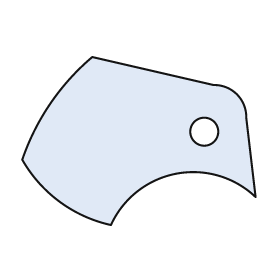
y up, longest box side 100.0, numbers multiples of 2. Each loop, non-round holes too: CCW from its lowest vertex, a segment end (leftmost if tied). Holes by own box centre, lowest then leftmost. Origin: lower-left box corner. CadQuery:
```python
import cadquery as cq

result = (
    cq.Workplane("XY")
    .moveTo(38.0, 0.0)
    .threePointArc((66.0, 22.0), (100.0, 12.0))
    .lineTo(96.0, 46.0)
    .threePointArc((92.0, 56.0), (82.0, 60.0))
    .lineTo(30.0, 72.0)
    .threePointArc((12.0, 52.0), (0.0, 28.0))
    .threePointArc((16.0, 10.0), (38.0, 0.0))
    .close()
    .moveTo(78.0, 40.0)
    .circle(6.0)
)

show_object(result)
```